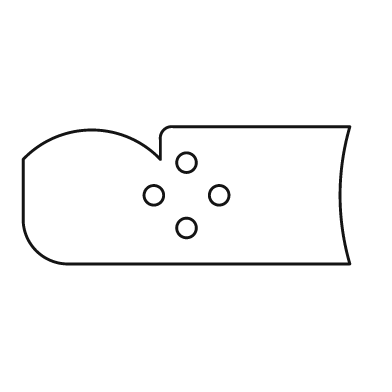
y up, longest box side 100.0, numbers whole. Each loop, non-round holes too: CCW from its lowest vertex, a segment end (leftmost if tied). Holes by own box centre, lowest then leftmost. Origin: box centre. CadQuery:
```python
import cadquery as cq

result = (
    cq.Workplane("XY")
    .moveTo(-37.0, -21.0)
    .lineTo(50.0, -21.0)
    .threePointArc((47.0, 0.0), (50.0, 21.0))
    .lineTo(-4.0, 21.0)
    .threePointArc((-7.0, 20.0), (-8.0, 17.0))
    .lineTo(-8.0, 11.0)
    .threePointArc((-29.0, 20.0), (-50.0, 11.0))
    .lineTo(-50.0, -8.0)
    .threePointArc((-46.0, -17.0), (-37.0, -21.0))
    .close()
    .moveTo(0.0, -10.0)
    .circle(3.0)
    .moveTo(-10.0, 0.0)
    .circle(3.0)
    .moveTo(10.0, 0.0)
    .circle(3.0)
    .moveTo(0.0, 10.0)
    .circle(3.0)
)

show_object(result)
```